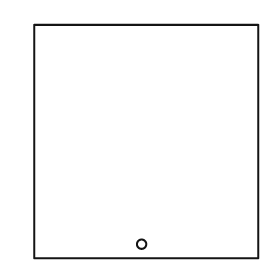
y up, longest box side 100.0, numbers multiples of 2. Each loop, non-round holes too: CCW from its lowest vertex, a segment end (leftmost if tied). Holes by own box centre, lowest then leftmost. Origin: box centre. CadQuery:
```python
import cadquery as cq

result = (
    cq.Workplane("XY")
    .moveTo(-48.0, -50.0)
    .lineTo(48.0, -50.0)
    .lineTo(48.0, 50.0)
    .lineTo(-48.0, 50.0)
    .close()
    .moveTo(-2.0, -44.0)
    .circle(2.0)
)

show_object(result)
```